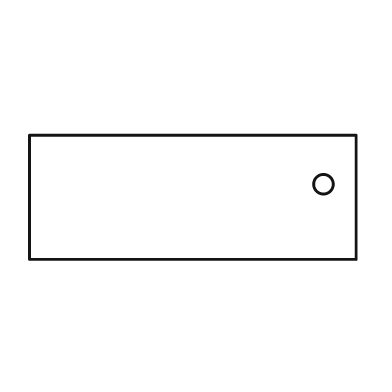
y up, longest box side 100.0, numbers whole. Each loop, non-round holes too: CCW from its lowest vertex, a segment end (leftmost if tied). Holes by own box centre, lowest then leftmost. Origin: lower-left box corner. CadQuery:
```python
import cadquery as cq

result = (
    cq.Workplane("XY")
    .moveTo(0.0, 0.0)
    .lineTo(100.0, 0.0)
    .lineTo(100.0, 38.0)
    .lineTo(0.0, 38.0)
    .close()
    .moveTo(90.0, 23.0)
    .circle(3.0)
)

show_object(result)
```